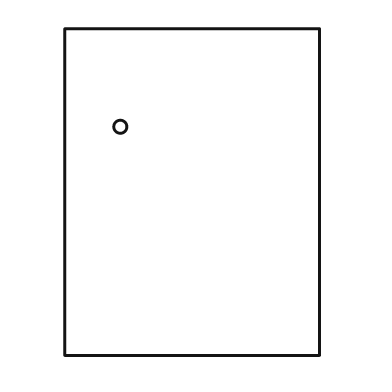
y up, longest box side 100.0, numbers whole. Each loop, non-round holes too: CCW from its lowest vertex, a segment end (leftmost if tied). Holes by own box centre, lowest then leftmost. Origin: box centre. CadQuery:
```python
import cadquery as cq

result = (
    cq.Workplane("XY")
    .moveTo(-39.0, -50.0)
    .lineTo(39.0, -50.0)
    .lineTo(39.0, 50.0)
    .lineTo(-39.0, 50.0)
    .close()
    .moveTo(-22.0, 20.0)
    .circle(2.0)
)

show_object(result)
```